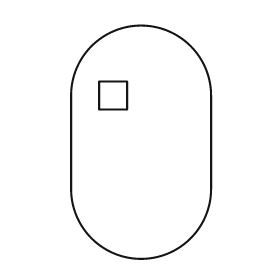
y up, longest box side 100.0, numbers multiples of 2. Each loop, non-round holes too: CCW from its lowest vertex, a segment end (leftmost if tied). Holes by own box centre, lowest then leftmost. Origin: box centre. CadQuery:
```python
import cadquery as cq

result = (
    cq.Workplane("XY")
    .moveTo(-30.0, -20.0)
    .threePointArc((0.0, -50.0), (30.0, -20.0))
    .lineTo(30.0, 20.0)
    .threePointArc((0.0, 50.0), (-30.0, 20.0))
    .close()
    .moveTo(-18.0, 14.0)
    .lineTo(-6.0, 14.0)
    .lineTo(-6.0, 26.0)
    .lineTo(-18.0, 26.0)
    .close()
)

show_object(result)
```